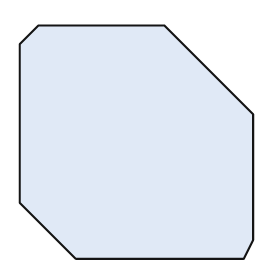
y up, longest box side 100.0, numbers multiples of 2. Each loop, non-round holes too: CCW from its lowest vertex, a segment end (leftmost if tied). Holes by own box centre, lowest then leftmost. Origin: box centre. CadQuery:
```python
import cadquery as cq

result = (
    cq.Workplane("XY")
    .moveTo(-26.0, -50.0)
    .lineTo(46.0, -50.0)
    .lineTo(50.0, -42.0)
    .lineTo(50.0, 12.0)
    .lineTo(12.0, 50.0)
    .lineTo(-42.0, 50.0)
    .lineTo(-50.0, 42.0)
    .lineTo(-50.0, -26.0)
    .close()
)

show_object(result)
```